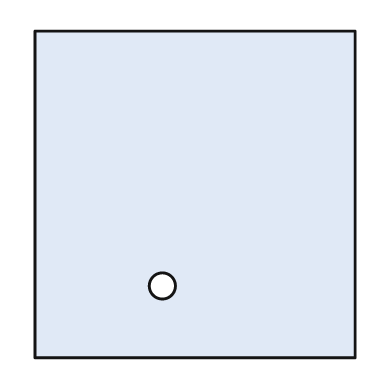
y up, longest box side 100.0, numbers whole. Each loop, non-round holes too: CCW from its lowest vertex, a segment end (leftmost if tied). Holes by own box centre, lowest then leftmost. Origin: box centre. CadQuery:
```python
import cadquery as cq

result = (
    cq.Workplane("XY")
    .moveTo(-49.0, -50.0)
    .lineTo(49.0, -50.0)
    .lineTo(49.0, 50.0)
    .lineTo(-49.0, 50.0)
    .close()
    .moveTo(-10.0, -28.0)
    .circle(4.0)
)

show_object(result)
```